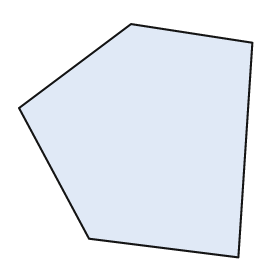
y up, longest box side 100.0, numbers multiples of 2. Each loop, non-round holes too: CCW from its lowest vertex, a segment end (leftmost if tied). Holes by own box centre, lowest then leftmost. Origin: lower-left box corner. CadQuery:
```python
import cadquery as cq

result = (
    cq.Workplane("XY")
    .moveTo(94.0, 0.0)
    .lineTo(100.0, 92.0)
    .lineTo(48.0, 100.0)
    .lineTo(0.0, 64.0)
    .lineTo(30.0, 8.0)
    .close()
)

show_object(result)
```